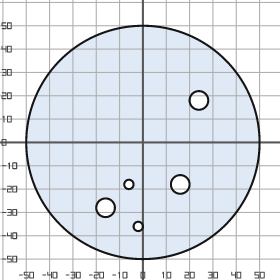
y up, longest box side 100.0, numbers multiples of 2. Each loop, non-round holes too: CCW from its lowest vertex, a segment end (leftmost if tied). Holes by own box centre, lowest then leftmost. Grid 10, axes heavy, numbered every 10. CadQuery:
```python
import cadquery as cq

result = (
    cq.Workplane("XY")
    .moveTo(0.0, 0.0)
    .circle(50.0)
    .moveTo(-2.0, -36.0)
    .circle(2.0)
    .moveTo(-16.0, -28.0)
    .circle(4.0)
    .moveTo(-6.0, -18.0)
    .circle(2.0)
    .moveTo(16.0, -18.0)
    .circle(4.0)
    .moveTo(24.0, 18.0)
    .circle(4.0)
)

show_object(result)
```